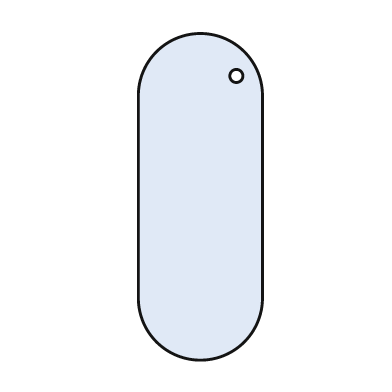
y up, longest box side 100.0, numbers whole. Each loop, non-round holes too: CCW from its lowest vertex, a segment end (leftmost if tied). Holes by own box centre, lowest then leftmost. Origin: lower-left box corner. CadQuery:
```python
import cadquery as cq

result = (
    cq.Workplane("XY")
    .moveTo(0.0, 19.0)
    .threePointArc((19.0, 0.0), (38.0, 19.0))
    .lineTo(38.0, 81.0)
    .threePointArc((19.0, 100.0), (0.0, 81.0))
    .close()
    .moveTo(30.0, 87.0)
    .circle(2.0)
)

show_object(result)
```